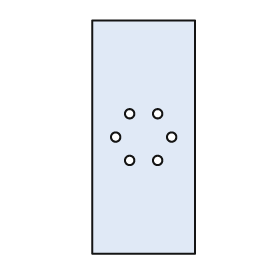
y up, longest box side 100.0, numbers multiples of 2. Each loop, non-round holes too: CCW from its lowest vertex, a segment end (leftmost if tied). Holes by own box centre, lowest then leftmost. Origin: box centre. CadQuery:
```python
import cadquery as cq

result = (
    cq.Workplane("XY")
    .moveTo(-22.0, -50.0)
    .lineTo(22.0, -50.0)
    .lineTo(22.0, 50.0)
    .lineTo(-22.0, 50.0)
    .close()
    .moveTo(-6.0, -10.0)
    .circle(2.0)
    .moveTo(6.0, -10.0)
    .circle(2.0)
    .moveTo(-12.0, 0.0)
    .circle(2.0)
    .moveTo(12.0, 0.0)
    .circle(2.0)
    .moveTo(-6.0, 10.0)
    .circle(2.0)
    .moveTo(6.0, 10.0)
    .circle(2.0)
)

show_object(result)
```